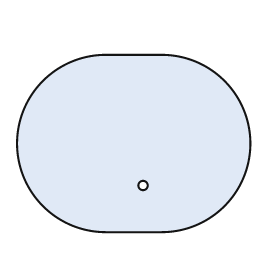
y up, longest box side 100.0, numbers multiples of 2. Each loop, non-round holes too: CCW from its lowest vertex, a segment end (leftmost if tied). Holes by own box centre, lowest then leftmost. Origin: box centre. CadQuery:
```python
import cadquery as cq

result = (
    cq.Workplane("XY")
    .moveTo(-12.0, -38.0)
    .lineTo(12.0, -38.0)
    .threePointArc((50.0, 0.0), (12.0, 38.0))
    .lineTo(-12.0, 38.0)
    .threePointArc((-50.0, 0.0), (-12.0, -38.0))
    .close()
    .moveTo(4.0, -18.0)
    .circle(2.0)
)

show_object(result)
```